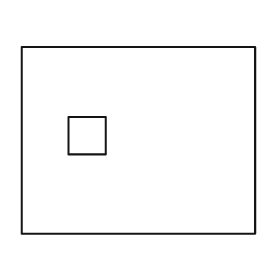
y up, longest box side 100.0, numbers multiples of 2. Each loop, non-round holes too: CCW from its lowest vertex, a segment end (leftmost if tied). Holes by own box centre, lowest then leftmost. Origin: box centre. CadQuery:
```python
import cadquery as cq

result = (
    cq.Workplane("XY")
    .moveTo(-50.0, -40.0)
    .lineTo(50.0, -40.0)
    .lineTo(50.0, 40.0)
    .lineTo(-50.0, 40.0)
    .close()
    .moveTo(-30.0, -6.0)
    .lineTo(-14.0, -6.0)
    .lineTo(-14.0, 10.0)
    .lineTo(-30.0, 10.0)
    .close()
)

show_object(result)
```